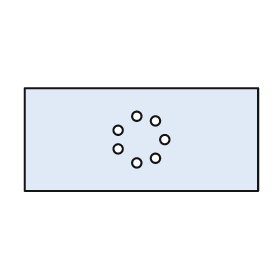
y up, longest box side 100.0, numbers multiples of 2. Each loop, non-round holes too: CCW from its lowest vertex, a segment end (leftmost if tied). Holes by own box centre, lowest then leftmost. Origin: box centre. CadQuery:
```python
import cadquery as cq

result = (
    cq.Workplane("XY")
    .moveTo(-50.0, -22.0)
    .lineTo(50.0, -22.0)
    .lineTo(50.0, 22.0)
    .lineTo(-50.0, 22.0)
    .close()
    .moveTo(-2.0, -10.0)
    .circle(2.0)
    .moveTo(6.0, -8.0)
    .circle(2.0)
    .moveTo(-10.0, -4.0)
    .circle(2.0)
    .moveTo(10.0, 0.0)
    .circle(2.0)
    .moveTo(-10.0, 4.0)
    .circle(2.0)
    .moveTo(6.0, 8.0)
    .circle(2.0)
    .moveTo(-2.0, 10.0)
    .circle(2.0)
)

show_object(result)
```